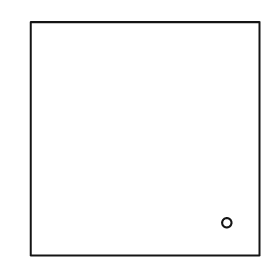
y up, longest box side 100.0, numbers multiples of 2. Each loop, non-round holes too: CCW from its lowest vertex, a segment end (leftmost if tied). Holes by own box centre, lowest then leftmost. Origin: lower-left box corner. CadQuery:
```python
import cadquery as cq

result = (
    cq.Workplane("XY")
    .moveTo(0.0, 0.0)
    .lineTo(98.0, 0.0)
    .lineTo(98.0, 100.0)
    .lineTo(0.0, 100.0)
    .close()
    .moveTo(84.0, 14.0)
    .circle(2.0)
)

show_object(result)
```